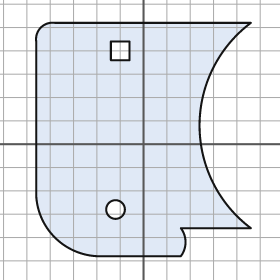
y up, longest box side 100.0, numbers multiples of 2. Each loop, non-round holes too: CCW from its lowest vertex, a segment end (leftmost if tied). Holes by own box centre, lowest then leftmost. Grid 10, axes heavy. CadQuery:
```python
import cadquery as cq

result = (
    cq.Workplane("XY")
    .moveTo(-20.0, -48.0)
    .lineTo(16.0, -48.0)
    .threePointArc((18.0, -42.0), (16.0, -36.0))
    .lineTo(46.0, -36.0)
    .threePointArc((24.0, 8.0), (46.0, 52.0))
    .lineTo(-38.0, 52.0)
    .threePointArc((-44.0, 50.0), (-46.0, 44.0))
    .lineTo(-46.0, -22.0)
    .threePointArc((-38.0, -40.0), (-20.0, -48.0))
    .close()
    .moveTo(-12.0, -28.0)
    .circle(4.0)
    .moveTo(-14.0, 36.0)
    .lineTo(-6.0, 36.0)
    .lineTo(-6.0, 44.0)
    .lineTo(-14.0, 44.0)
    .close()
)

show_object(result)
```